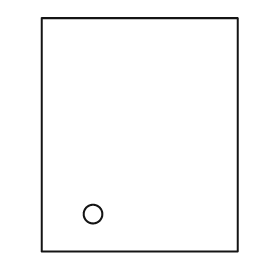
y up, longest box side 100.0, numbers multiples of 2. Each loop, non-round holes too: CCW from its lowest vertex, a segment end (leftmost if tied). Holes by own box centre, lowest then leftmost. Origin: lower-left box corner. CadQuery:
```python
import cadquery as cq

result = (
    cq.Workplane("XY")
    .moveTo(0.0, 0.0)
    .lineTo(84.0, 0.0)
    .lineTo(84.0, 100.0)
    .lineTo(0.0, 100.0)
    .close()
    .moveTo(22.0, 16.0)
    .circle(4.0)
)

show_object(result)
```